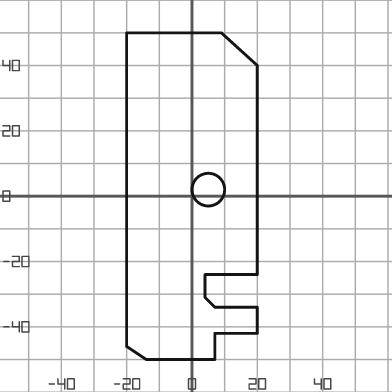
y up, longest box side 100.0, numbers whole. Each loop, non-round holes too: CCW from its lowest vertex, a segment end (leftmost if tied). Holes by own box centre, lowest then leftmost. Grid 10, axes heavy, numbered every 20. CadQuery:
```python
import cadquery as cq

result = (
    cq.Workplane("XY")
    .moveTo(-14.0, -50.0)
    .lineTo(7.0, -50.0)
    .lineTo(7.0, -42.0)
    .lineTo(20.0, -42.0)
    .lineTo(20.0, -34.0)
    .lineTo(7.0, -34.0)
    .lineTo(4.0, -31.0)
    .lineTo(4.0, -24.0)
    .lineTo(20.0, -24.0)
    .lineTo(20.0, 40.0)
    .lineTo(9.0, 50.0)
    .lineTo(-20.0, 50.0)
    .lineTo(-20.0, -46.0)
    .close()
    .moveTo(5.0, 2.0)
    .circle(5.0)
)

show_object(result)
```